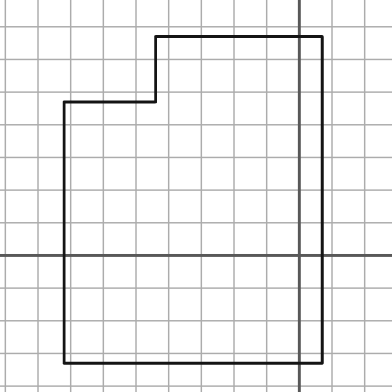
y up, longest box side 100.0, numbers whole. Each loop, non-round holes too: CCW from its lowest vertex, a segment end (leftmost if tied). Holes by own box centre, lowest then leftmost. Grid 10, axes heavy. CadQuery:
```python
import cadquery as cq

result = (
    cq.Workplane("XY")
    .moveTo(-72.0, -33.0)
    .lineTo(7.0, -33.0)
    .lineTo(7.0, 67.0)
    .lineTo(-44.0, 67.0)
    .lineTo(-44.0, 47.0)
    .lineTo(-72.0, 47.0)
    .close()
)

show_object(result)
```